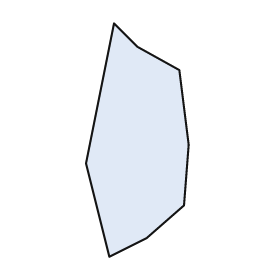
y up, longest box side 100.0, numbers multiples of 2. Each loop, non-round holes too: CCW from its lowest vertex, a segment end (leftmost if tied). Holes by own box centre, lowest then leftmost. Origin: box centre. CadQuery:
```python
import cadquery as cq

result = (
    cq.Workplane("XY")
    .moveTo(-12.0, -50.0)
    .lineTo(4.0, -42.0)
    .lineTo(20.0, -28.0)
    .lineTo(22.0, -2.0)
    .lineTo(18.0, 30.0)
    .lineTo(0.0, 40.0)
    .lineTo(-10.0, 50.0)
    .lineTo(-22.0, -10.0)
    .close()
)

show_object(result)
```